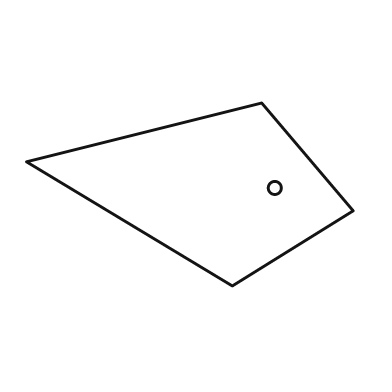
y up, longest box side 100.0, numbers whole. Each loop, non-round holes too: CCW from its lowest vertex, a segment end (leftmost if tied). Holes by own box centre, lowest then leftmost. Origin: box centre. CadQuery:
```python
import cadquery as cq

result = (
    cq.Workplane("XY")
    .moveTo(13.0, -28.0)
    .lineTo(50.0, -5.0)
    .lineTo(22.0, 28.0)
    .lineTo(-50.0, 10.0)
    .close()
    .moveTo(26.0, 2.0)
    .circle(2.0)
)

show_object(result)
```